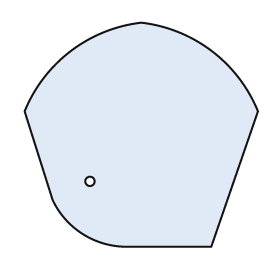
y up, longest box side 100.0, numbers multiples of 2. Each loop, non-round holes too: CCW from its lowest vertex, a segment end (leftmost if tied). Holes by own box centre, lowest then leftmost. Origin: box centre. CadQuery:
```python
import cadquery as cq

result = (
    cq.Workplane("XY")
    .moveTo(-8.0, -48.0)
    .lineTo(30.0, -48.0)
    .lineTo(50.0, 10.0)
    .threePointArc((30.0, 36.0), (0.0, 48.0))
    .threePointArc((-30.0, 36.0), (-50.0, 10.0))
    .lineTo(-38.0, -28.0)
    .threePointArc((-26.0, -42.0), (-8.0, -48.0))
    .close()
    .moveTo(-22.0, -20.0)
    .circle(2.0)
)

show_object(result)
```